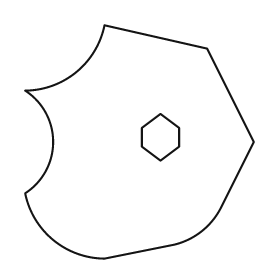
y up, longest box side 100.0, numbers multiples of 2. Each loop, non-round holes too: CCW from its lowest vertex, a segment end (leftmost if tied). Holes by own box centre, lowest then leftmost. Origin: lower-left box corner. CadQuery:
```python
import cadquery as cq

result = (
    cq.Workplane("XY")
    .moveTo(34.0, 0.0)
    .lineTo(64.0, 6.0)
    .threePointArc((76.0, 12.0), (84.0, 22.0))
    .lineTo(98.0, 50.0)
    .lineTo(78.0, 90.0)
    .lineTo(34.0, 100.0)
    .threePointArc((22.0, 80.0), (0.0, 72.0))
    .threePointArc((12.0, 50.0), (0.0, 28.0))
    .threePointArc((12.0, 8.0), (34.0, 0.0))
    .close()
    .moveTo(58.0, 42.0)
    .lineTo(66.0, 48.0)
    .lineTo(66.0, 56.0)
    .lineTo(58.0, 62.0)
    .lineTo(50.0, 56.0)
    .lineTo(50.0, 48.0)
    .close()
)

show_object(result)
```